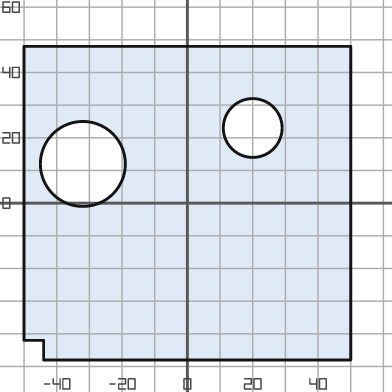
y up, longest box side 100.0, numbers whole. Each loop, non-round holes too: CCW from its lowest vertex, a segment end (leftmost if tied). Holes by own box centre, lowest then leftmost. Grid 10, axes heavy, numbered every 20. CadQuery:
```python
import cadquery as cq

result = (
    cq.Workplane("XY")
    .moveTo(-44.0, -48.0)
    .lineTo(50.0, -48.0)
    .lineTo(50.0, 48.0)
    .lineTo(-50.0, 48.0)
    .lineTo(-50.0, -42.0)
    .lineTo(-44.0, -42.0)
    .close()
    .moveTo(-32.0, 12.0)
    .circle(13.0)
    .moveTo(20.0, 23.0)
    .circle(9.0)
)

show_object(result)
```